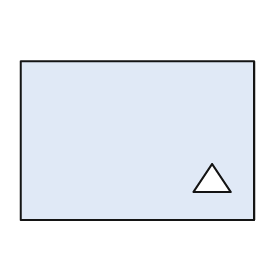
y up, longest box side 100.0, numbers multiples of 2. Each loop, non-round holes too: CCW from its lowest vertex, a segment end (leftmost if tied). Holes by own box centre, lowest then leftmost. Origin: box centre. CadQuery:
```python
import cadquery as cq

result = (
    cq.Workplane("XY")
    .moveTo(-50.0, -34.0)
    .lineTo(50.0, -34.0)
    .lineTo(50.0, 34.0)
    .lineTo(-50.0, 34.0)
    .close()
    .moveTo(24.0, -22.0)
    .lineTo(40.0, -22.0)
    .lineTo(32.0, -10.0)
    .close()
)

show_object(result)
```